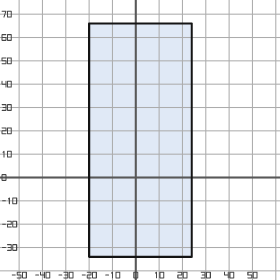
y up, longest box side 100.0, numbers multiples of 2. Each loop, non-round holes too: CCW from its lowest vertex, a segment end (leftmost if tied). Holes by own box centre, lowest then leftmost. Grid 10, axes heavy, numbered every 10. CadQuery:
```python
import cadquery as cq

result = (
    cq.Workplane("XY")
    .moveTo(-20.0, -34.0)
    .lineTo(24.0, -34.0)
    .lineTo(24.0, 66.0)
    .lineTo(-20.0, 66.0)
    .close()
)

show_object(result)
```